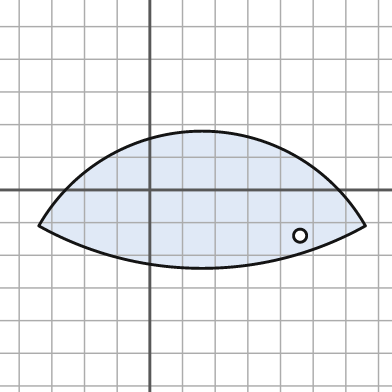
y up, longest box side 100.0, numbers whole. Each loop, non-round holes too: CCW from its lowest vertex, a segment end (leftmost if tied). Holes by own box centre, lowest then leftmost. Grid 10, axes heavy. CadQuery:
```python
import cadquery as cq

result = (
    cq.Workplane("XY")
    .moveTo(-34.0, -11.0)
    .threePointArc((16.0, -24.0), (66.0, -11.0))
    .threePointArc((16.0, 18.0), (-34.0, -11.0))
    .close()
    .moveTo(46.0, -14.0)
    .circle(2.0)
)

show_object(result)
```